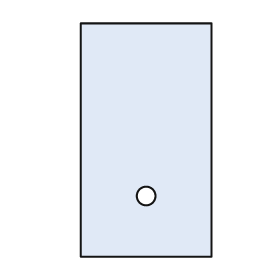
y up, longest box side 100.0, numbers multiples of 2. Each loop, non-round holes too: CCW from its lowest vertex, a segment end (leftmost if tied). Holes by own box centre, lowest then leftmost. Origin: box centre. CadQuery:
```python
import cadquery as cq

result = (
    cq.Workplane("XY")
    .moveTo(-28.0, -50.0)
    .lineTo(28.0, -50.0)
    .lineTo(28.0, 50.0)
    .lineTo(-28.0, 50.0)
    .close()
    .moveTo(0.0, -24.0)
    .circle(4.0)
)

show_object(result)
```